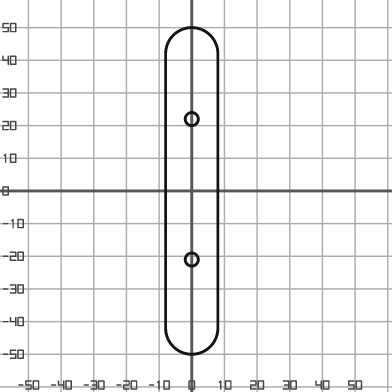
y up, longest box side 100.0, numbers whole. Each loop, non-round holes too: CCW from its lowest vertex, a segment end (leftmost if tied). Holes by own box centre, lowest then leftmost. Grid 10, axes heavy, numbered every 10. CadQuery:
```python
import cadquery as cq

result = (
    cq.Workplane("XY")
    .moveTo(-8.0, -42.0)
    .threePointArc((0.0, -50.0), (8.0, -42.0))
    .lineTo(8.0, 42.0)
    .threePointArc((0.0, 50.0), (-8.0, 42.0))
    .close()
    .moveTo(0.0, -21.0)
    .circle(2.0)
    .moveTo(0.0, 22.0)
    .circle(2.0)
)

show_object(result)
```